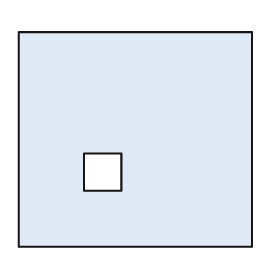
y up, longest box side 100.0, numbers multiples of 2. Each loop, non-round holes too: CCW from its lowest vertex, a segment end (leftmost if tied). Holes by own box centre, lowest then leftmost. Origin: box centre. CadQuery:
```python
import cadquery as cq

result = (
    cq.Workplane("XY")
    .moveTo(-50.0, -46.0)
    .lineTo(50.0, -46.0)
    .lineTo(50.0, 46.0)
    .lineTo(-50.0, 46.0)
    .close()
    .moveTo(-22.0, -22.0)
    .lineTo(-6.0, -22.0)
    .lineTo(-6.0, -6.0)
    .lineTo(-22.0, -6.0)
    .close()
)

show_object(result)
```